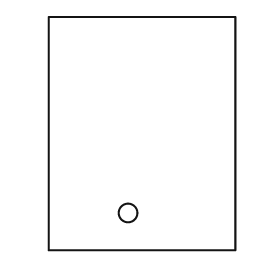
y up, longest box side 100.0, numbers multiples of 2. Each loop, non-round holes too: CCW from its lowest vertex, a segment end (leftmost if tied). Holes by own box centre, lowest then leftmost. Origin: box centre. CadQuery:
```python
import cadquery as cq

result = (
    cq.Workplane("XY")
    .moveTo(-40.0, -50.0)
    .lineTo(40.0, -50.0)
    .lineTo(40.0, 50.0)
    .lineTo(-40.0, 50.0)
    .close()
    .moveTo(-6.0, -34.0)
    .circle(4.0)
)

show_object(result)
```